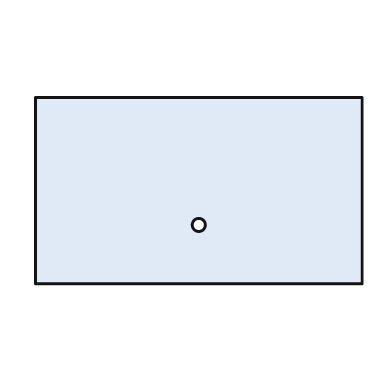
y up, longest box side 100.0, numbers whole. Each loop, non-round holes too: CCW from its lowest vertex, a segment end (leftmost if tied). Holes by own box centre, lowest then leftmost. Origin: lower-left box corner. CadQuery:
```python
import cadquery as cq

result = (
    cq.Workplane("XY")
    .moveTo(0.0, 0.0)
    .lineTo(100.0, 0.0)
    .lineTo(100.0, 57.0)
    .lineTo(0.0, 57.0)
    .close()
    .moveTo(50.0, 18.0)
    .circle(2.0)
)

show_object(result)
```